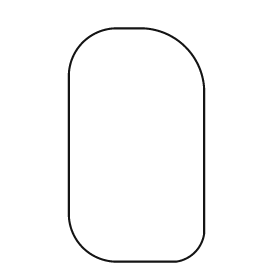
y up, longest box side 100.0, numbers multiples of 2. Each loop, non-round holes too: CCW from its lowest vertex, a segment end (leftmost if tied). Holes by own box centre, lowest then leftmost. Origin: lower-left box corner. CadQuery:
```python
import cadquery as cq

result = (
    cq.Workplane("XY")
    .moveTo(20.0, 0.0)
    .lineTo(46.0, 0.0)
    .threePointArc((54.0, 4.0), (58.0, 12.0))
    .lineTo(58.0, 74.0)
    .threePointArc((50.0, 92.0), (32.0, 100.0))
    .lineTo(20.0, 100.0)
    .threePointArc((6.0, 94.0), (0.0, 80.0))
    .lineTo(0.0, 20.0)
    .threePointArc((6.0, 6.0), (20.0, 0.0))
    .close()
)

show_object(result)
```